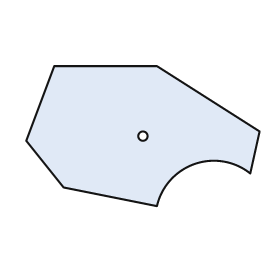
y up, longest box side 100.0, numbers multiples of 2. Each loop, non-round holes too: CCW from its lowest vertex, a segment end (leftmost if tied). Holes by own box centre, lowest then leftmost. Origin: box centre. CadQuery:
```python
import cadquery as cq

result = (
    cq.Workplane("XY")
    .moveTo(6.0, -30.0)
    .threePointArc((22.0, -12.0), (46.0, -16.0))
    .lineTo(50.0, 2.0)
    .lineTo(6.0, 30.0)
    .lineTo(-38.0, 30.0)
    .lineTo(-50.0, -2.0)
    .lineTo(-34.0, -22.0)
    .close()
    .moveTo(0.0, 0.0)
    .circle(2.0)
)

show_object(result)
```